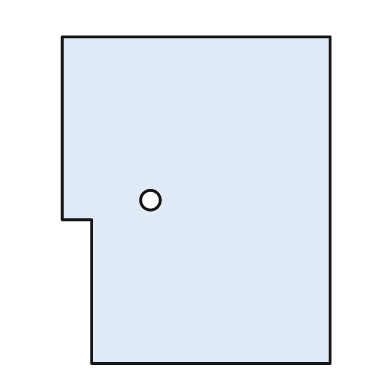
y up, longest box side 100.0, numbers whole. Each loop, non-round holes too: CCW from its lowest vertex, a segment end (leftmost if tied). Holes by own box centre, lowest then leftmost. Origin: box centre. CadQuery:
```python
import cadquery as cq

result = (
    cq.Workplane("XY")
    .moveTo(-32.0, -50.0)
    .lineTo(41.0, -50.0)
    .lineTo(41.0, 50.0)
    .lineTo(-41.0, 50.0)
    .lineTo(-41.0, -6.0)
    .lineTo(-32.0, -6.0)
    .close()
    .moveTo(-14.0, 0.0)
    .circle(3.0)
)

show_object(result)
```